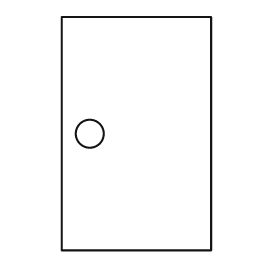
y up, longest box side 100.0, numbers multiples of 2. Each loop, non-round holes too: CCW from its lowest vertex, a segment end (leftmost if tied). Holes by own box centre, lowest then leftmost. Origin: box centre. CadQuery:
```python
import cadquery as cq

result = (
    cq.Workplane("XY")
    .moveTo(-32.0, -50.0)
    .lineTo(32.0, -50.0)
    .lineTo(32.0, 50.0)
    .lineTo(-32.0, 50.0)
    .close()
    .moveTo(-20.0, 0.0)
    .circle(6.0)
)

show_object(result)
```